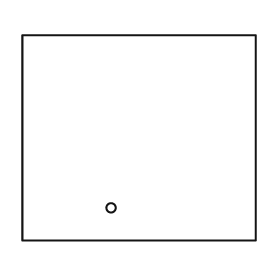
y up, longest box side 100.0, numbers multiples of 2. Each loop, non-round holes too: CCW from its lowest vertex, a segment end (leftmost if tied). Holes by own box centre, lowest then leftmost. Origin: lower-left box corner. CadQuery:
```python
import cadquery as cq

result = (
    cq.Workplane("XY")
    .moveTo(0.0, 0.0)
    .lineTo(100.0, 0.0)
    .lineTo(100.0, 88.0)
    .lineTo(0.0, 88.0)
    .close()
    .moveTo(38.0, 14.0)
    .circle(2.0)
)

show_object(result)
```